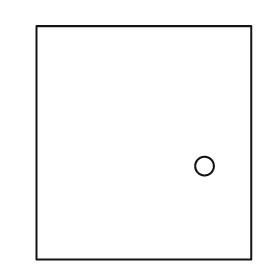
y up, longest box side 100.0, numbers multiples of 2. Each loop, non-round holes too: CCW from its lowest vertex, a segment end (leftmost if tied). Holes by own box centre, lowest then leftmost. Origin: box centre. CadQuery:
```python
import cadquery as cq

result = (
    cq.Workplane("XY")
    .moveTo(-46.0, -50.0)
    .lineTo(46.0, -50.0)
    .lineTo(46.0, 50.0)
    .lineTo(-46.0, 50.0)
    .close()
    .moveTo(26.0, -10.0)
    .circle(4.0)
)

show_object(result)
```